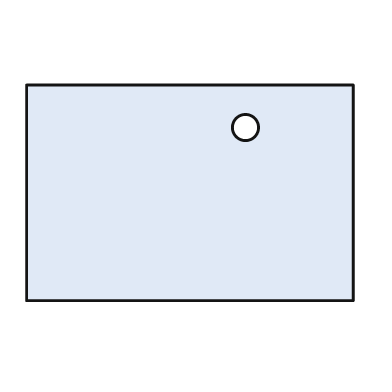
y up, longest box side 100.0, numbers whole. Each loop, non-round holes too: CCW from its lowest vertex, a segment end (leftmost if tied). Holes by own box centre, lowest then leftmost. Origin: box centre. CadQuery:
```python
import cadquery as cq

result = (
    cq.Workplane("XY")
    .moveTo(-50.0, -33.0)
    .lineTo(50.0, -33.0)
    .lineTo(50.0, 33.0)
    .lineTo(-50.0, 33.0)
    .close()
    .moveTo(17.0, 20.0)
    .circle(4.0)
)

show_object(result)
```